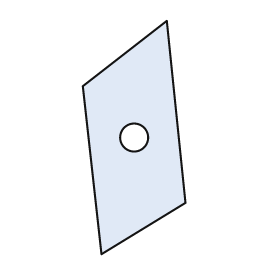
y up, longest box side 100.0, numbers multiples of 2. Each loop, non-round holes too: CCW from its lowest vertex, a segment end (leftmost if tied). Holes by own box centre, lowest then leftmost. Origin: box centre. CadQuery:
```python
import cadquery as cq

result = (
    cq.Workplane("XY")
    .moveTo(-14.0, -50.0)
    .lineTo(22.0, -28.0)
    .lineTo(14.0, 50.0)
    .lineTo(-22.0, 22.0)
    .close()
    .moveTo(0.0, 0.0)
    .circle(6.0)
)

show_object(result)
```